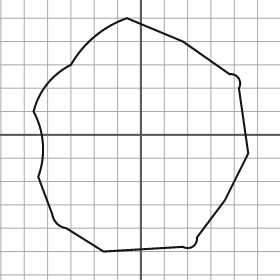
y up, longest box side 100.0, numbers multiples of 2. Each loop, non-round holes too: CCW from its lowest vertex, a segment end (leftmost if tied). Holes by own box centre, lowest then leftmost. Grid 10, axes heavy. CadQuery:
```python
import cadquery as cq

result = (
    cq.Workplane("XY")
    .moveTo(-16.0, -50.0)
    .lineTo(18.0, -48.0)
    .threePointArc((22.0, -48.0), (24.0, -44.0))
    .lineTo(36.0, -28.0)
    .lineTo(46.0, -8.0)
    .lineTo(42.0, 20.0)
    .threePointArc((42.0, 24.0), (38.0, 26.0))
    .lineTo(18.0, 40.0)
    .lineTo(-6.0, 50.0)
    .threePointArc((-20.0, 42.0), (-30.0, 30.0))
    .threePointArc((-40.0, 22.0), (-46.0, 10.0))
    .threePointArc((-42.0, -4.0), (-44.0, -18.0))
    .lineTo(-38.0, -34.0)
    .threePointArc((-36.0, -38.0), (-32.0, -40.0))
    .close()
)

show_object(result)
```